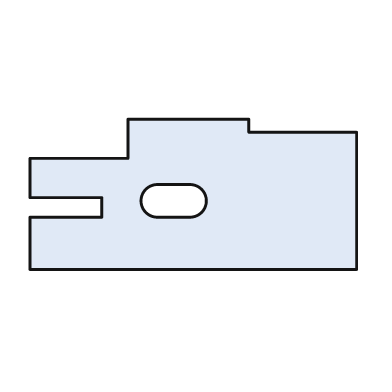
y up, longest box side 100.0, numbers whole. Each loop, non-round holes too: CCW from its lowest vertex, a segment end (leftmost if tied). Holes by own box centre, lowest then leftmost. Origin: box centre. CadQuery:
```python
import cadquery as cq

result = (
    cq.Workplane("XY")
    .moveTo(-50.0, -23.0)
    .lineTo(50.0, -23.0)
    .lineTo(50.0, 19.0)
    .lineTo(17.0, 19.0)
    .lineTo(17.0, 23.0)
    .lineTo(-20.0, 23.0)
    .lineTo(-20.0, 11.0)
    .lineTo(-50.0, 11.0)
    .lineTo(-50.0, -1.0)
    .lineTo(-28.0, -1.0)
    .lineTo(-28.0, -7.0)
    .lineTo(-50.0, -7.0)
    .close()
    .moveTo(-11.0, -7.0)
    .lineTo(-1.0, -7.0)
    .threePointArc((4.0, -2.0), (-1.0, 3.0))
    .lineTo(-11.0, 3.0)
    .threePointArc((-16.0, -2.0), (-11.0, -7.0))
    .close()
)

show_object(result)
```